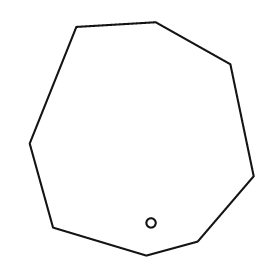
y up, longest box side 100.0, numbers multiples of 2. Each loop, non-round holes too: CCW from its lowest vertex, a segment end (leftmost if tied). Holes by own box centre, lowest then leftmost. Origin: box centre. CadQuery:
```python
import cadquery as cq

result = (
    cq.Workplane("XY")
    .moveTo(2.0, -50.0)
    .lineTo(24.0, -44.0)
    .lineTo(48.0, -16.0)
    .lineTo(38.0, 32.0)
    .lineTo(6.0, 50.0)
    .lineTo(-28.0, 48.0)
    .lineTo(-48.0, -2.0)
    .lineTo(-38.0, -38.0)
    .close()
    .moveTo(4.0, -36.0)
    .circle(2.0)
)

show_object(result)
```